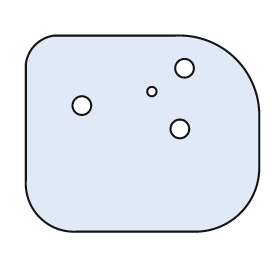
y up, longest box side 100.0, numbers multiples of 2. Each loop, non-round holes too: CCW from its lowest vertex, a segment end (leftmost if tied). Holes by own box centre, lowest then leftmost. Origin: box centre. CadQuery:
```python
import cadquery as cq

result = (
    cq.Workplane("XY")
    .moveTo(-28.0, -42.0)
    .lineTo(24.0, -42.0)
    .threePointArc((42.0, -34.0), (50.0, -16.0))
    .lineTo(50.0, 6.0)
    .threePointArc((40.0, 32.0), (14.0, 42.0))
    .lineTo(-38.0, 42.0)
    .threePointArc((-46.0, 38.0), (-50.0, 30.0))
    .lineTo(-50.0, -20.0)
    .threePointArc((-44.0, -36.0), (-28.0, -42.0))
    .close()
    .moveTo(16.0, 2.0)
    .circle(4.0)
    .moveTo(-26.0, 12.0)
    .circle(4.0)
    .moveTo(4.0, 18.0)
    .circle(2.0)
    .moveTo(18.0, 28.0)
    .circle(4.0)
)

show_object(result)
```